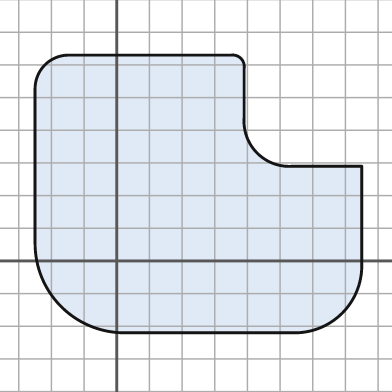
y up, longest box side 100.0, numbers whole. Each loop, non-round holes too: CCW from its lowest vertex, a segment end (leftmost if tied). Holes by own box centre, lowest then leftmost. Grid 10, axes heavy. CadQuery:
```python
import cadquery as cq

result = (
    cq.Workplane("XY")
    .moveTo(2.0, -22.0)
    .lineTo(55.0, -22.0)
    .threePointArc((69.0, -16.0), (75.0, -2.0))
    .lineTo(75.0, 29.0)
    .lineTo(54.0, 29.0)
    .threePointArc((43.0, 33.0), (39.0, 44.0))
    .lineTo(39.0, 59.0)
    .threePointArc((38.0, 62.0), (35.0, 63.0))
    .lineTo(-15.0, 63.0)
    .threePointArc((-22.0, 60.0), (-25.0, 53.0))
    .lineTo(-25.0, 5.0)
    .threePointArc((-17.0, -14.0), (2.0, -22.0))
    .close()
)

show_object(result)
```